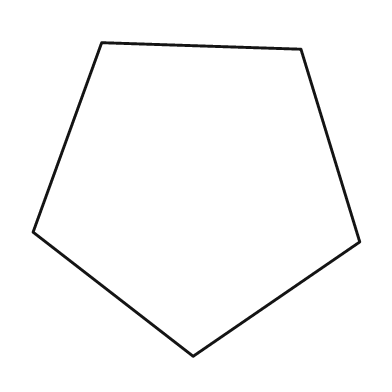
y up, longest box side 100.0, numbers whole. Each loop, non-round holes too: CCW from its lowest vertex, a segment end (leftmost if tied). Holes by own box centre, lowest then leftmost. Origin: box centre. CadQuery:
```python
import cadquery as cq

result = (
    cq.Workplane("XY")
    .moveTo(-1.0, -48.0)
    .lineTo(50.0, -13.0)
    .lineTo(32.0, 46.0)
    .lineTo(-29.0, 48.0)
    .lineTo(-50.0, -10.0)
    .close()
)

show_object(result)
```